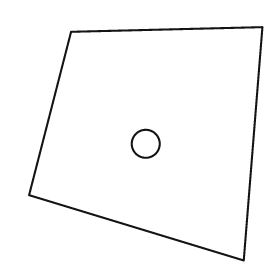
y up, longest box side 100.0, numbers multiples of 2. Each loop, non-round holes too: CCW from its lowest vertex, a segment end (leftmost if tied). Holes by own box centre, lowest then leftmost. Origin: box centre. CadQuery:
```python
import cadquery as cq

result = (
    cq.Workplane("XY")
    .moveTo(42.0, -50.0)
    .lineTo(50.0, 50.0)
    .lineTo(-32.0, 48.0)
    .lineTo(-50.0, -22.0)
    .close()
    .moveTo(0.0, 0.0)
    .circle(6.0)
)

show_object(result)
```